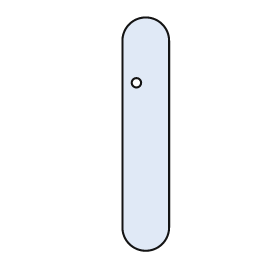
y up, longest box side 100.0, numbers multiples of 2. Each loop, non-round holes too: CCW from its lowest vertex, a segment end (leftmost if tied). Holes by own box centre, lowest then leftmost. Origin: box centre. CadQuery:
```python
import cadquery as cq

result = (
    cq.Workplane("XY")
    .moveTo(-10.0, -40.0)
    .threePointArc((0.0, -50.0), (10.0, -40.0))
    .lineTo(10.0, 40.0)
    .threePointArc((0.0, 50.0), (-10.0, 40.0))
    .close()
    .moveTo(-4.0, 22.0)
    .circle(2.0)
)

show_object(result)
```